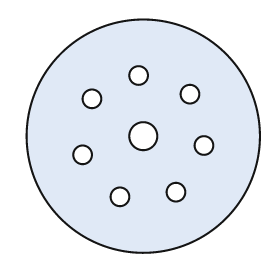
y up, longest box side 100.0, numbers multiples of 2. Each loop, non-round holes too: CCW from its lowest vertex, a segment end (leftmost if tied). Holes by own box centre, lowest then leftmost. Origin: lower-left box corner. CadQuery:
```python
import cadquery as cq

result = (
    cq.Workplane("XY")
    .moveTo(50.0, 50.0)
    .circle(50.0)
    .moveTo(40.0, 24.0)
    .circle(4.0)
    .moveTo(64.0, 26.0)
    .circle(4.0)
    .moveTo(24.0, 42.0)
    .circle(4.0)
    .moveTo(76.0, 46.0)
    .circle(4.0)
    .moveTo(50.0, 50.0)
    .circle(6.0)
    .moveTo(28.0, 66.0)
    .circle(4.0)
    .moveTo(70.0, 68.0)
    .circle(4.0)
    .moveTo(48.0, 76.0)
    .circle(4.0)
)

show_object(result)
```